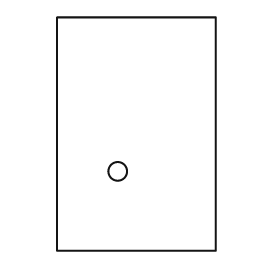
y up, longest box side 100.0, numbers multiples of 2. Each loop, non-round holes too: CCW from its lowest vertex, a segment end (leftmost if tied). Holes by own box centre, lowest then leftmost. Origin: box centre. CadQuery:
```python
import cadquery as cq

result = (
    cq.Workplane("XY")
    .moveTo(-34.0, -50.0)
    .lineTo(34.0, -50.0)
    .lineTo(34.0, 50.0)
    .lineTo(-34.0, 50.0)
    .close()
    .moveTo(-8.0, -16.0)
    .circle(4.0)
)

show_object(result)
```